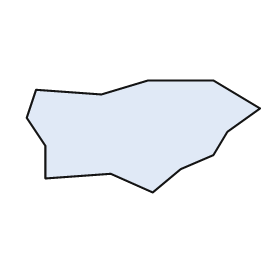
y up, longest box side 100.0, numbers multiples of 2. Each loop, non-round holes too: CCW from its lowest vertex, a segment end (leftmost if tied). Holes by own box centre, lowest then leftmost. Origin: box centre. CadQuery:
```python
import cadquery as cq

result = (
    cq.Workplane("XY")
    .moveTo(4.0, -24.0)
    .lineTo(16.0, -14.0)
    .lineTo(30.0, -8.0)
    .lineTo(36.0, 2.0)
    .lineTo(50.0, 12.0)
    .lineTo(30.0, 24.0)
    .lineTo(2.0, 24.0)
    .lineTo(-18.0, 18.0)
    .lineTo(-46.0, 20.0)
    .lineTo(-50.0, 8.0)
    .lineTo(-42.0, -4.0)
    .lineTo(-42.0, -18.0)
    .lineTo(-14.0, -16.0)
    .close()
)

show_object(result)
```